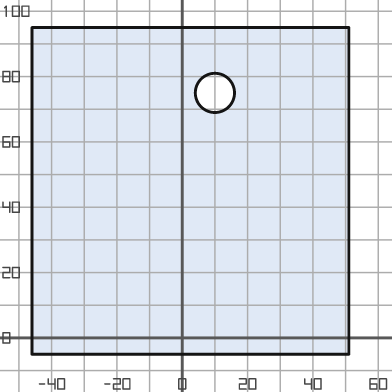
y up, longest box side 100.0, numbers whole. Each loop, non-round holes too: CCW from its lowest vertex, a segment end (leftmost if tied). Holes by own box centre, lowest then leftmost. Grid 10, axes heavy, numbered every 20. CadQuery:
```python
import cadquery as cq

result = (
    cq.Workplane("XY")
    .moveTo(-46.0, -5.0)
    .lineTo(51.0, -5.0)
    .lineTo(51.0, 95.0)
    .lineTo(-46.0, 95.0)
    .close()
    .moveTo(10.0, 75.0)
    .circle(6.0)
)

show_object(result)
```